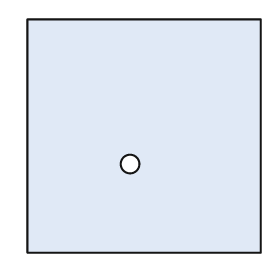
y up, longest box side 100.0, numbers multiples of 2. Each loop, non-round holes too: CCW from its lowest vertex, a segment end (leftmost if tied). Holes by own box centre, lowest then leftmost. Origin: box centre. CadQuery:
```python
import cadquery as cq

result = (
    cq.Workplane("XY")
    .moveTo(-50.0, -50.0)
    .lineTo(50.0, -50.0)
    .lineTo(50.0, 50.0)
    .lineTo(-50.0, 50.0)
    .close()
    .moveTo(-6.0, -12.0)
    .circle(4.0)
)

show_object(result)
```